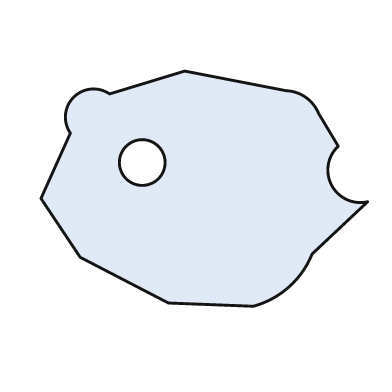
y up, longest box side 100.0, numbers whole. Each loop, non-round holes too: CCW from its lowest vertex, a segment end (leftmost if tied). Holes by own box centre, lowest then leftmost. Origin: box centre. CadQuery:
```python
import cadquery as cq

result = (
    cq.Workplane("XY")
    .moveTo(15.0, -36.0)
    .threePointArc((26.0, -30.0), (33.0, -20.0))
    .lineTo(50.0, -4.0)
    .threePointArc((39.0, 1.0), (41.0, 13.0))
    .lineTo(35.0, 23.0)
    .threePointArc((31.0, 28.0), (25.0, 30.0))
    .lineTo(-6.0, 36.0)
    .lineTo(-29.0, 29.0)
    .threePointArc((-40.0, 28.0), (-41.0, 17.0))
    .lineTo(-50.0, -3.0)
    .lineTo(-38.0, -21.0)
    .lineTo(-11.0, -35.0)
    .close()
    .moveTo(-19.0, 8.0)
    .circle(7.0)
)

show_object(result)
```